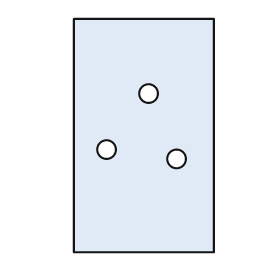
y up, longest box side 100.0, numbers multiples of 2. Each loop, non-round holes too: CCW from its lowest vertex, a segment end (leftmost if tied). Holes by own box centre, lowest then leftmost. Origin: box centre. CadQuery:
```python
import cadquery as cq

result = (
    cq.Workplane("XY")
    .moveTo(-30.0, -50.0)
    .lineTo(30.0, -50.0)
    .lineTo(30.0, 50.0)
    .lineTo(-30.0, 50.0)
    .close()
    .moveTo(14.0, -10.0)
    .circle(4.0)
    .moveTo(-16.0, -6.0)
    .circle(4.0)
    .moveTo(2.0, 18.0)
    .circle(4.0)
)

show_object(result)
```